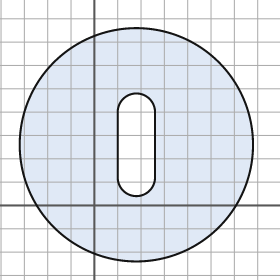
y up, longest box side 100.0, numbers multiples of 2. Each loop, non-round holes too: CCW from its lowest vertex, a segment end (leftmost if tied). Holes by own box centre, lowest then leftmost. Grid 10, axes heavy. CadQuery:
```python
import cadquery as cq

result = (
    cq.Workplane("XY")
    .moveTo(18.0, 26.0)
    .circle(50.0)
    .moveTo(10.0, 12.0)
    .threePointArc((18.0, 4.0), (26.0, 12.0))
    .lineTo(26.0, 40.0)
    .threePointArc((18.0, 48.0), (10.0, 40.0))
    .close()
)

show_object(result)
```